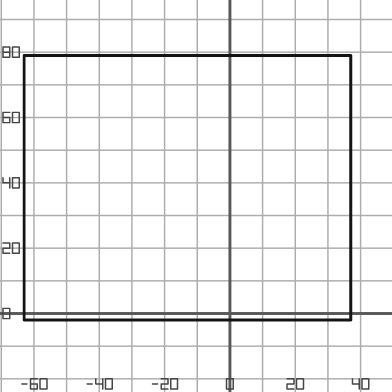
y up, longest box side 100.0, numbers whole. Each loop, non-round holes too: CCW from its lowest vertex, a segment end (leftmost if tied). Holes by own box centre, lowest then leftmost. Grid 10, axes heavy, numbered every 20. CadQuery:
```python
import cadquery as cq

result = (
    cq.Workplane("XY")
    .moveTo(-63.0, -2.0)
    .lineTo(37.0, -2.0)
    .lineTo(37.0, 79.0)
    .lineTo(-63.0, 79.0)
    .close()
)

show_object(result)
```